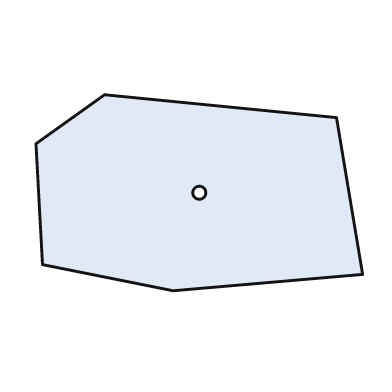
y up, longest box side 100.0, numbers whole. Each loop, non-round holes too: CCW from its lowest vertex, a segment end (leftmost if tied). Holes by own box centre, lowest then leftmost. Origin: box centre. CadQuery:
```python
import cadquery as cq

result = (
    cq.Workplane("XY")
    .moveTo(-8.0, -30.0)
    .lineTo(50.0, -25.0)
    .lineTo(42.0, 23.0)
    .lineTo(-29.0, 30.0)
    .lineTo(-50.0, 15.0)
    .lineTo(-48.0, -22.0)
    .close()
    .moveTo(0.0, 0.0)
    .circle(2.0)
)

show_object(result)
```